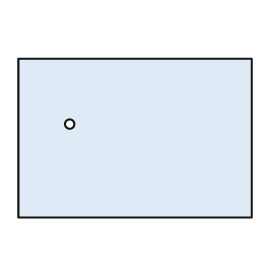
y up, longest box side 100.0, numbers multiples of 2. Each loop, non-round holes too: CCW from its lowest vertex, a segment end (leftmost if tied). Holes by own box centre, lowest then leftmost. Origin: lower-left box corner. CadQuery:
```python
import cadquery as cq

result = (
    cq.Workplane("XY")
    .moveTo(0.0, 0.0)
    .lineTo(100.0, 0.0)
    .lineTo(100.0, 68.0)
    .lineTo(0.0, 68.0)
    .close()
    .moveTo(22.0, 40.0)
    .circle(2.0)
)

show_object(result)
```